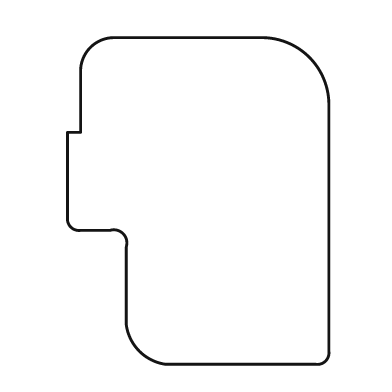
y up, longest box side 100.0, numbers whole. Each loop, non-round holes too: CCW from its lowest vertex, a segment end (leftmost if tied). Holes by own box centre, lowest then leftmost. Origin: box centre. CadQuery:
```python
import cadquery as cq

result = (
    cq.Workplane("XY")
    .moveTo(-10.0, -50.0)
    .lineTo(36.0, -50.0)
    .threePointArc((39.0, -49.0), (40.0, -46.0))
    .lineTo(40.0, 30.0)
    .threePointArc((34.0, 44.0), (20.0, 50.0))
    .lineTo(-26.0, 50.0)
    .threePointArc((-33.0, 47.0), (-36.0, 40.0))
    .lineTo(-36.0, 21.0)
    .lineTo(-40.0, 21.0)
    .lineTo(-40.0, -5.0)
    .threePointArc((-39.0, -8.0), (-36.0, -9.0))
    .lineTo(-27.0, -9.0)
    .threePointArc((-23.0, -10.0), (-22.0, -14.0))
    .lineTo(-22.0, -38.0)
    .threePointArc((-18.0, -46.0), (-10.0, -50.0))
    .close()
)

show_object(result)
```